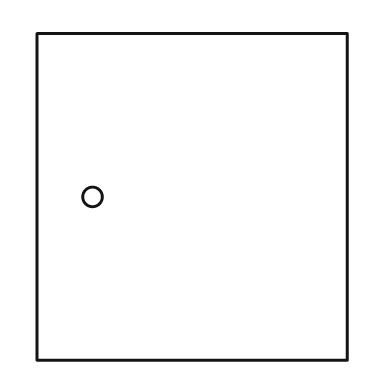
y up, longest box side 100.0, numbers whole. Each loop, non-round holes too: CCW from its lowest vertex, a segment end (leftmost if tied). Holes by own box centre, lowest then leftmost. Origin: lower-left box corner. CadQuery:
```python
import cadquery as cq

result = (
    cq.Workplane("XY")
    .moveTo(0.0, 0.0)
    .lineTo(95.0, 0.0)
    .lineTo(95.0, 100.0)
    .lineTo(0.0, 100.0)
    .close()
    .moveTo(17.0, 50.0)
    .circle(3.0)
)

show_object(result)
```